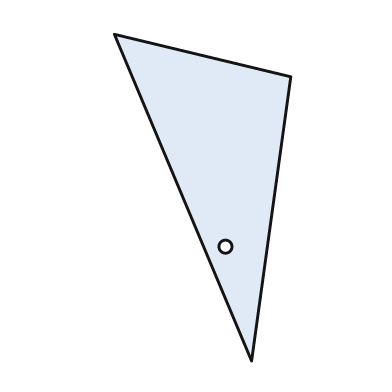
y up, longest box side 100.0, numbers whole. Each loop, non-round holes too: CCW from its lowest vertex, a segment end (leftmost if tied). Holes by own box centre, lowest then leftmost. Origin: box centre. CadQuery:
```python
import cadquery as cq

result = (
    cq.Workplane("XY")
    .moveTo(15.0, -50.0)
    .lineTo(27.0, 37.0)
    .lineTo(-27.0, 50.0)
    .close()
    .moveTo(7.0, -15.0)
    .circle(2.0)
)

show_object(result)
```